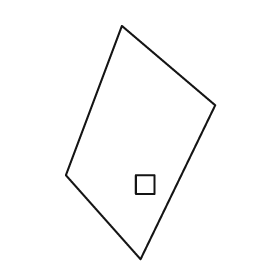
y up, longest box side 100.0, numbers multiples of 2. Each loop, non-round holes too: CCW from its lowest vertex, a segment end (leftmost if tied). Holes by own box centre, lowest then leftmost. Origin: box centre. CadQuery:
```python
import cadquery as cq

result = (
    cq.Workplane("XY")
    .moveTo(0.0, -50.0)
    .lineTo(32.0, 16.0)
    .lineTo(-8.0, 50.0)
    .lineTo(-32.0, -14.0)
    .close()
    .moveTo(-2.0, -22.0)
    .lineTo(6.0, -22.0)
    .lineTo(6.0, -14.0)
    .lineTo(-2.0, -14.0)
    .close()
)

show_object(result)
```